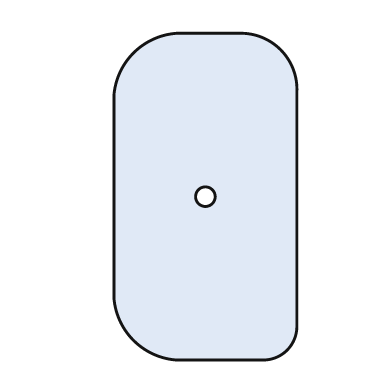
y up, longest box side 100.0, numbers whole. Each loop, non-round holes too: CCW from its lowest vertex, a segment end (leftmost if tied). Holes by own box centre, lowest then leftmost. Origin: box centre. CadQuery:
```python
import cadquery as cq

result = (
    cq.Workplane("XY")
    .moveTo(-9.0, -50.0)
    .lineTo(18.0, -50.0)
    .threePointArc((25.0, -47.0), (28.0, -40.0))
    .lineTo(28.0, 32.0)
    .threePointArc((23.0, 45.0), (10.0, 50.0))
    .lineTo(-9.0, 50.0)
    .threePointArc((-22.0, 44.0), (-28.0, 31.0))
    .lineTo(-28.0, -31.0)
    .threePointArc((-22.0, -44.0), (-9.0, -50.0))
    .close()
    .moveTo(0.0, 0.0)
    .circle(3.0)
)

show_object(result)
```